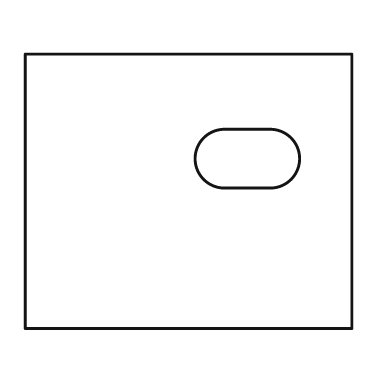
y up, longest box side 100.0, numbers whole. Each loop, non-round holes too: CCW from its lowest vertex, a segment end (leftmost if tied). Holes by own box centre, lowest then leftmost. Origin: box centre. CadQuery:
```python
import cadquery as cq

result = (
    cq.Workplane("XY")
    .moveTo(-50.0, -42.0)
    .lineTo(50.0, -42.0)
    .lineTo(50.0, 42.0)
    .lineTo(-50.0, 42.0)
    .close()
    .moveTo(11.0, 1.0)
    .lineTo(25.0, 1.0)
    .threePointArc((34.0, 10.0), (25.0, 19.0))
    .lineTo(11.0, 19.0)
    .threePointArc((2.0, 10.0), (11.0, 1.0))
    .close()
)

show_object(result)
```